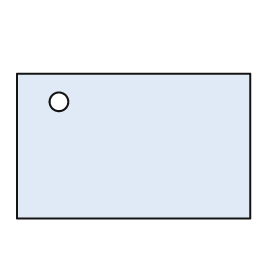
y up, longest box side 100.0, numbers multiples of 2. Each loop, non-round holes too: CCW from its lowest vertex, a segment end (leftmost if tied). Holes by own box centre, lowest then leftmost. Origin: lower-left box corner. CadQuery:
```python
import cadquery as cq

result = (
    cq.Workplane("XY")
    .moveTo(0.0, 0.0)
    .lineTo(100.0, 0.0)
    .lineTo(100.0, 62.0)
    .lineTo(0.0, 62.0)
    .close()
    .moveTo(18.0, 50.0)
    .circle(4.0)
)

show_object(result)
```